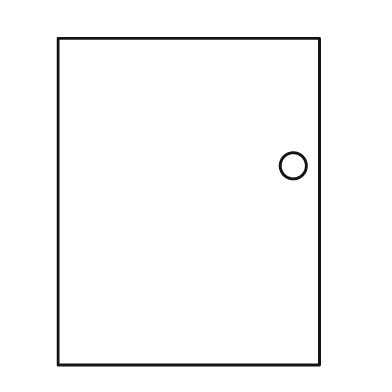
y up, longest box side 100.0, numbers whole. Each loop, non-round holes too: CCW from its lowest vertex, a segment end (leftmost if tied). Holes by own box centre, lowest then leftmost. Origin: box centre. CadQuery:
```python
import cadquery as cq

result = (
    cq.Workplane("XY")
    .moveTo(-40.0, -50.0)
    .lineTo(40.0, -50.0)
    .lineTo(40.0, 50.0)
    .lineTo(-40.0, 50.0)
    .close()
    .moveTo(32.0, 11.0)
    .circle(4.0)
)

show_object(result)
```